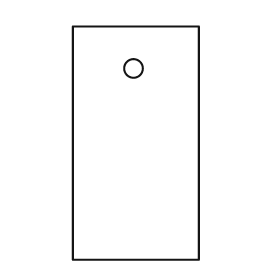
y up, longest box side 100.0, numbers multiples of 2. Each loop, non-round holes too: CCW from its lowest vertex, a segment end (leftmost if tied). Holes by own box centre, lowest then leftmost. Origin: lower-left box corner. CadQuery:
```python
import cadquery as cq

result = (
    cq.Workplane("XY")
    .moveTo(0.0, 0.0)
    .lineTo(54.0, 0.0)
    .lineTo(54.0, 100.0)
    .lineTo(0.0, 100.0)
    .close()
    .moveTo(26.0, 82.0)
    .circle(4.0)
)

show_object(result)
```